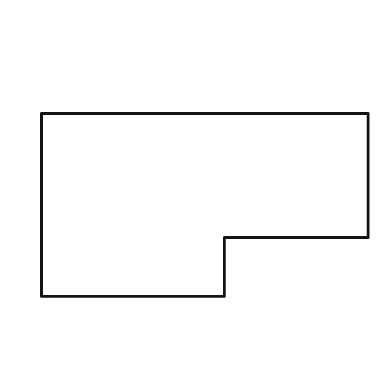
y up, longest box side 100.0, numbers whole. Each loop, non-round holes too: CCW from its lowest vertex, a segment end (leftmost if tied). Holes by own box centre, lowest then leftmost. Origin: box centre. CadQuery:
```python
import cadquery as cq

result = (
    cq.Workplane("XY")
    .moveTo(-50.0, -28.0)
    .lineTo(6.0, -28.0)
    .lineTo(6.0, -10.0)
    .lineTo(50.0, -10.0)
    .lineTo(50.0, 28.0)
    .lineTo(-50.0, 28.0)
    .close()
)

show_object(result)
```